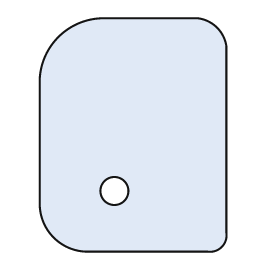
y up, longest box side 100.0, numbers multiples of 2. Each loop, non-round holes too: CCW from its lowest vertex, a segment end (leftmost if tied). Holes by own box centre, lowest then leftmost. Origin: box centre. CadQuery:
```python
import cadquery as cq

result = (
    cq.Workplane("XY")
    .moveTo(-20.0, -50.0)
    .lineTo(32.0, -50.0)
    .threePointArc((38.0, -48.0), (40.0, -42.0))
    .lineTo(40.0, 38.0)
    .threePointArc((36.0, 46.0), (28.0, 50.0))
    .lineTo(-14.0, 50.0)
    .threePointArc((-32.0, 42.0), (-40.0, 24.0))
    .lineTo(-40.0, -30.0)
    .threePointArc((-34.0, -44.0), (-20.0, -50.0))
    .close()
    .moveTo(-8.0, -24.0)
    .circle(6.0)
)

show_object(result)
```